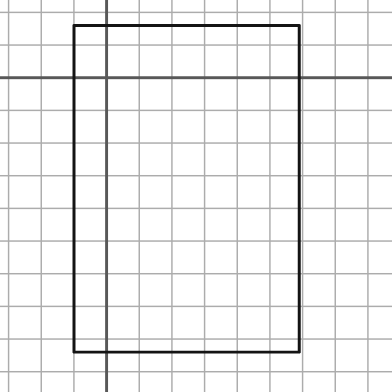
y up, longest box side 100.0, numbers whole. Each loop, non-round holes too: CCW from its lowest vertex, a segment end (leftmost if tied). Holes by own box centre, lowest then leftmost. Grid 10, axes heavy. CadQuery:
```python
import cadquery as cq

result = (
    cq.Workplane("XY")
    .moveTo(-10.0, -84.0)
    .lineTo(59.0, -84.0)
    .lineTo(59.0, 16.0)
    .lineTo(-10.0, 16.0)
    .close()
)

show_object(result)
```